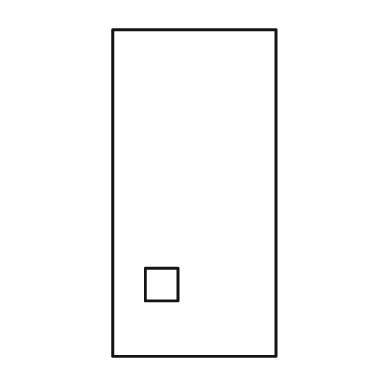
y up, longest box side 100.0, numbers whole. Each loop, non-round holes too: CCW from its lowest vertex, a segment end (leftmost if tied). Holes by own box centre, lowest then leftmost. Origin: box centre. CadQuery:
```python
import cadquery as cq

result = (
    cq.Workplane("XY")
    .moveTo(-25.0, -50.0)
    .lineTo(25.0, -50.0)
    .lineTo(25.0, 50.0)
    .lineTo(-25.0, 50.0)
    .close()
    .moveTo(-15.0, -33.0)
    .lineTo(-5.0, -33.0)
    .lineTo(-5.0, -23.0)
    .lineTo(-15.0, -23.0)
    .close()
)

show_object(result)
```